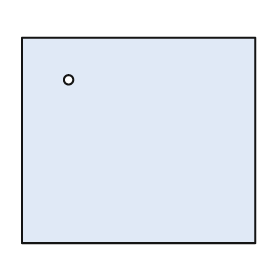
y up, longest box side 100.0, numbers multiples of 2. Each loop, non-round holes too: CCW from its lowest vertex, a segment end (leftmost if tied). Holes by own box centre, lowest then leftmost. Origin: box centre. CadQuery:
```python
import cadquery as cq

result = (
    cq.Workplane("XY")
    .moveTo(-50.0, -44.0)
    .lineTo(50.0, -44.0)
    .lineTo(50.0, 44.0)
    .lineTo(-50.0, 44.0)
    .close()
    .moveTo(-30.0, 26.0)
    .circle(2.0)
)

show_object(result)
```